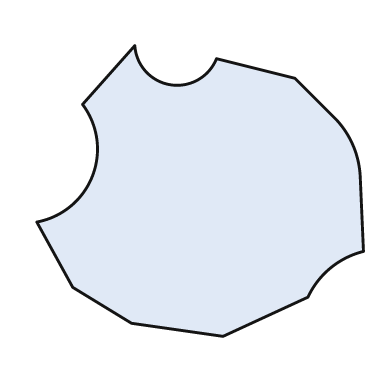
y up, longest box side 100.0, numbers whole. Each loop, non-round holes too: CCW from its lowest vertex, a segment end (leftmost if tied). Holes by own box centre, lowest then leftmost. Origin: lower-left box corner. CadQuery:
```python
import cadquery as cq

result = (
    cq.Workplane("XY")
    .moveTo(57.0, 0.0)
    .lineTo(83.0, 12.0)
    .threePointArc((90.0, 21.0), (100.0, 26.0))
    .lineTo(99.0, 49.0)
    .threePointArc((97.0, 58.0), (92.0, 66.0))
    .lineTo(79.0, 79.0)
    .lineTo(55.0, 85.0)
    .threePointArc((41.0, 77.0), (30.0, 89.0))
    .lineTo(14.0, 71.0)
    .threePointArc((17.0, 49.0), (0.0, 35.0))
    .lineTo(11.0, 15.0)
    .lineTo(29.0, 4.0)
    .close()
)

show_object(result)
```